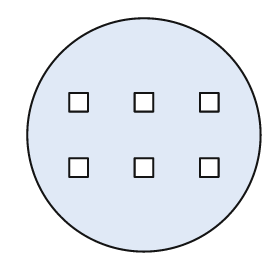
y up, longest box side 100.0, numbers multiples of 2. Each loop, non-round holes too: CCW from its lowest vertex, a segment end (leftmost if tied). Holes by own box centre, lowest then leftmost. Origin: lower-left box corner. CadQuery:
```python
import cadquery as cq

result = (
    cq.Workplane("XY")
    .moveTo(50.0, 50.0)
    .circle(50.0)
    .moveTo(18.0, 32.0)
    .lineTo(26.0, 32.0)
    .lineTo(26.0, 40.0)
    .lineTo(18.0, 40.0)
    .close()
    .moveTo(46.0, 32.0)
    .lineTo(54.0, 32.0)
    .lineTo(54.0, 40.0)
    .lineTo(46.0, 40.0)
    .close()
    .moveTo(74.0, 32.0)
    .lineTo(82.0, 32.0)
    .lineTo(82.0, 40.0)
    .lineTo(74.0, 40.0)
    .close()
    .moveTo(18.0, 60.0)
    .lineTo(26.0, 60.0)
    .lineTo(26.0, 68.0)
    .lineTo(18.0, 68.0)
    .close()
    .moveTo(46.0, 60.0)
    .lineTo(54.0, 60.0)
    .lineTo(54.0, 68.0)
    .lineTo(46.0, 68.0)
    .close()
    .moveTo(74.0, 60.0)
    .lineTo(82.0, 60.0)
    .lineTo(82.0, 68.0)
    .lineTo(74.0, 68.0)
    .close()
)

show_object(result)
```